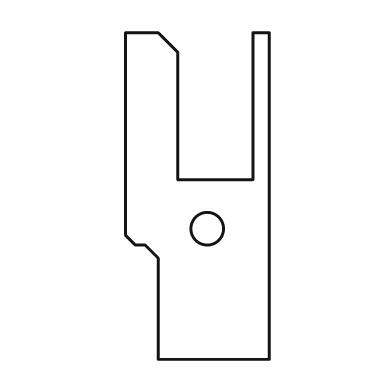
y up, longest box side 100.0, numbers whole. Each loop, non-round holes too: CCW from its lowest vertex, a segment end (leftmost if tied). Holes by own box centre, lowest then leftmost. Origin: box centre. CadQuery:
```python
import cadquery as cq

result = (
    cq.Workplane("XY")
    .moveTo(-12.0, -50.0)
    .lineTo(22.0, -50.0)
    .lineTo(22.0, 50.0)
    .lineTo(17.0, 50.0)
    .lineTo(17.0, 5.0)
    .lineTo(-6.0, 5.0)
    .lineTo(-6.0, 44.0)
    .lineTo(-12.0, 50.0)
    .lineTo(-22.0, 50.0)
    .lineTo(-22.0, -12.0)
    .lineTo(-19.0, -15.0)
    .lineTo(-16.0, -15.0)
    .lineTo(-12.0, -19.0)
    .close()
    .moveTo(3.0, -10.0)
    .circle(5.0)
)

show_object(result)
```